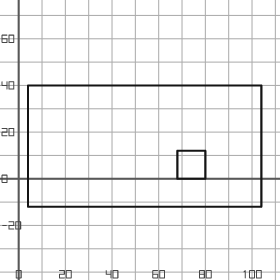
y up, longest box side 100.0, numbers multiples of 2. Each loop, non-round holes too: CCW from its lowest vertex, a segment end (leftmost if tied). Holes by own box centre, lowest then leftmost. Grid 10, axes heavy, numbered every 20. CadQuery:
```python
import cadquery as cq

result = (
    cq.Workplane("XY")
    .moveTo(4.0, -12.0)
    .lineTo(104.0, -12.0)
    .lineTo(104.0, 40.0)
    .lineTo(4.0, 40.0)
    .close()
    .moveTo(68.0, 0.0)
    .lineTo(80.0, 0.0)
    .lineTo(80.0, 12.0)
    .lineTo(68.0, 12.0)
    .close()
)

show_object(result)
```